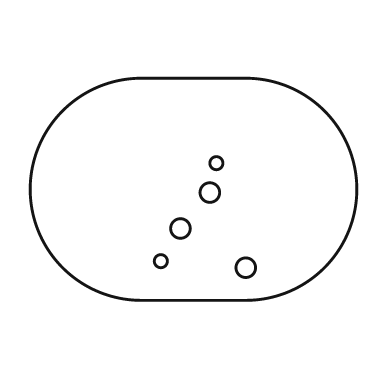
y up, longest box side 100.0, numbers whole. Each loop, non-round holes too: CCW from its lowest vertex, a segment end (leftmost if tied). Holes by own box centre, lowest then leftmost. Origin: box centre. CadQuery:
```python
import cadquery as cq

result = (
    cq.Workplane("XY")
    .moveTo(-16.0, -34.0)
    .lineTo(16.0, -34.0)
    .threePointArc((50.0, 0.0), (16.0, 34.0))
    .lineTo(-16.0, 34.0)
    .threePointArc((-50.0, 0.0), (-16.0, -34.0))
    .close()
    .moveTo(16.0, -24.0)
    .circle(3.0)
    .moveTo(-10.0, -22.0)
    .circle(2.0)
    .moveTo(-4.0, -12.0)
    .circle(3.0)
    .moveTo(5.0, -1.0)
    .circle(3.0)
    .moveTo(7.0, 8.0)
    .circle(2.0)
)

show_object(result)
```